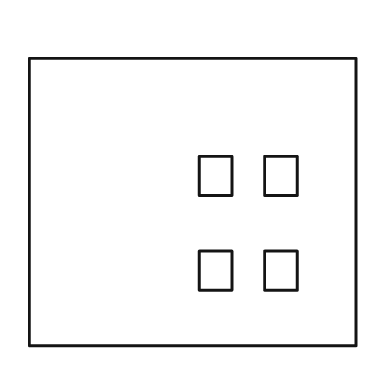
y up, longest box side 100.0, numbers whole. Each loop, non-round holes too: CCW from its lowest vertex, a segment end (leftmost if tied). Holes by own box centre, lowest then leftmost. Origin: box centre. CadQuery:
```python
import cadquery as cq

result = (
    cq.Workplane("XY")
    .moveTo(-50.0, -44.0)
    .lineTo(50.0, -44.0)
    .lineTo(50.0, 44.0)
    .lineTo(-50.0, 44.0)
    .close()
    .moveTo(2.0, -27.0)
    .lineTo(12.0, -27.0)
    .lineTo(12.0, -15.0)
    .lineTo(2.0, -15.0)
    .close()
    .moveTo(22.0, -27.0)
    .lineTo(32.0, -27.0)
    .lineTo(32.0, -15.0)
    .lineTo(22.0, -15.0)
    .close()
    .moveTo(2.0, 2.0)
    .lineTo(12.0, 2.0)
    .lineTo(12.0, 14.0)
    .lineTo(2.0, 14.0)
    .close()
    .moveTo(22.0, 2.0)
    .lineTo(32.0, 2.0)
    .lineTo(32.0, 14.0)
    .lineTo(22.0, 14.0)
    .close()
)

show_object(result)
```